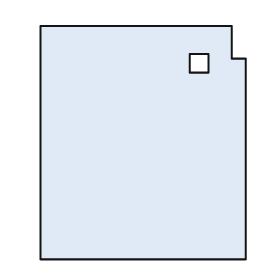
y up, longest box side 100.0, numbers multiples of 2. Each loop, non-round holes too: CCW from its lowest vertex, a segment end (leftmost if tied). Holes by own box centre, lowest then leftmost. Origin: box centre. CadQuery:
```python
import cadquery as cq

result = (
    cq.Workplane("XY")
    .moveTo(-44.0, -50.0)
    .lineTo(44.0, -50.0)
    .lineTo(44.0, 36.0)
    .lineTo(38.0, 36.0)
    .lineTo(38.0, 50.0)
    .lineTo(-44.0, 50.0)
    .close()
    .moveTo(20.0, 30.0)
    .lineTo(28.0, 30.0)
    .lineTo(28.0, 38.0)
    .lineTo(20.0, 38.0)
    .close()
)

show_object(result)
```